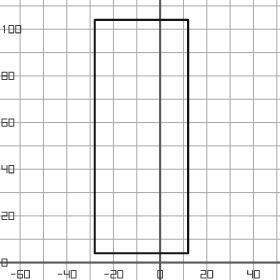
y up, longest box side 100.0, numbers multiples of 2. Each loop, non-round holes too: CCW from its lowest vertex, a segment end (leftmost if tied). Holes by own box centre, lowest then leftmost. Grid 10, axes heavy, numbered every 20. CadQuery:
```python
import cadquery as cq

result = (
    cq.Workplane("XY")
    .moveTo(-28.0, 4.0)
    .lineTo(12.0, 4.0)
    .lineTo(12.0, 104.0)
    .lineTo(-28.0, 104.0)
    .close()
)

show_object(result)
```